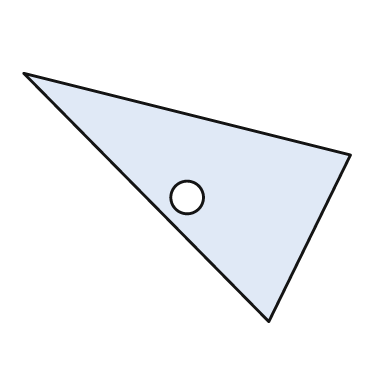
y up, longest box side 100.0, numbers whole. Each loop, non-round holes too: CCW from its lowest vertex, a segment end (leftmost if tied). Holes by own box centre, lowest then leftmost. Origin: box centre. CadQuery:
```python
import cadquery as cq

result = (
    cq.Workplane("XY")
    .moveTo(25.0, -38.0)
    .lineTo(50.0, 13.0)
    .lineTo(-50.0, 38.0)
    .close()
    .moveTo(0.0, 0.0)
    .circle(5.0)
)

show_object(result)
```